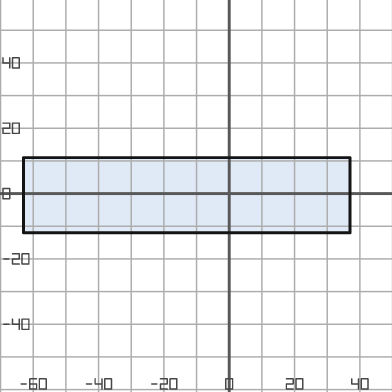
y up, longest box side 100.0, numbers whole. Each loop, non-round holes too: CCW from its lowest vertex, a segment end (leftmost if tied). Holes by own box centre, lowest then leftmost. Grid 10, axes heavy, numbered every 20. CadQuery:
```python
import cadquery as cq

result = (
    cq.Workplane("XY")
    .moveTo(-63.0, -12.0)
    .lineTo(37.0, -12.0)
    .lineTo(37.0, 11.0)
    .lineTo(-63.0, 11.0)
    .close()
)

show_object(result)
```